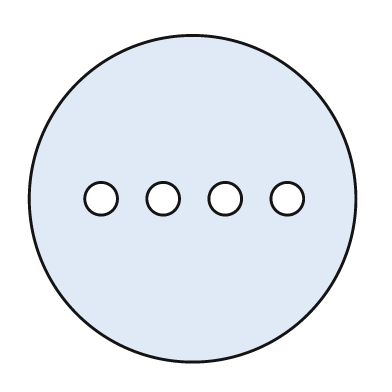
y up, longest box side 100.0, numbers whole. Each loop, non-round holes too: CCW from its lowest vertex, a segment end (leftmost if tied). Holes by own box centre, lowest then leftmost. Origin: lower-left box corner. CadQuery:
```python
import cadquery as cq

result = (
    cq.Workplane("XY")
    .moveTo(50.0, 50.0)
    .circle(50.0)
    .moveTo(22.0, 50.0)
    .circle(5.0)
    .moveTo(41.0, 50.0)
    .circle(5.0)
    .moveTo(60.0, 50.0)
    .circle(5.0)
    .moveTo(79.0, 50.0)
    .circle(5.0)
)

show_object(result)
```